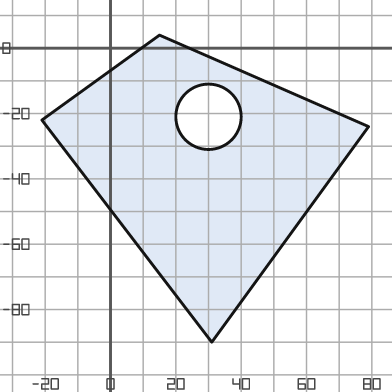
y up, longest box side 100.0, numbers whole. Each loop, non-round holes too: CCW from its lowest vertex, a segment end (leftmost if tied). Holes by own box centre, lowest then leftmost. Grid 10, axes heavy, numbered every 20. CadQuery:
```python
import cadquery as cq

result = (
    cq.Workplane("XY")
    .moveTo(31.0, -90.0)
    .lineTo(79.0, -24.0)
    .lineTo(15.0, 4.0)
    .lineTo(-21.0, -22.0)
    .close()
    .moveTo(30.0, -21.0)
    .circle(10.0)
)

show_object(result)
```